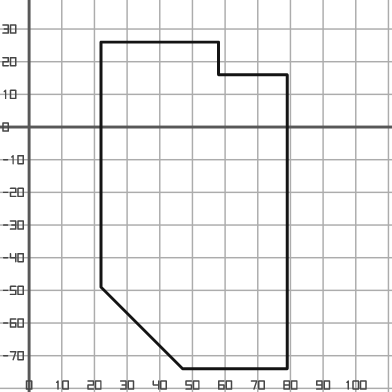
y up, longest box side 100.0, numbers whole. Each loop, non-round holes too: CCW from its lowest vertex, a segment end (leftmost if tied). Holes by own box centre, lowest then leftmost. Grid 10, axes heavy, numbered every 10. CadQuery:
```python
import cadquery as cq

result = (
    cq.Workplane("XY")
    .moveTo(47.0, -74.0)
    .lineTo(79.0, -74.0)
    .lineTo(79.0, 16.0)
    .lineTo(58.0, 16.0)
    .lineTo(58.0, 26.0)
    .lineTo(22.0, 26.0)
    .lineTo(22.0, -49.0)
    .close()
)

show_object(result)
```